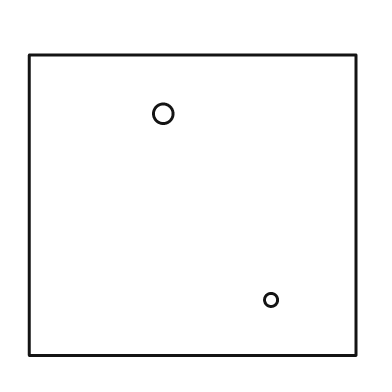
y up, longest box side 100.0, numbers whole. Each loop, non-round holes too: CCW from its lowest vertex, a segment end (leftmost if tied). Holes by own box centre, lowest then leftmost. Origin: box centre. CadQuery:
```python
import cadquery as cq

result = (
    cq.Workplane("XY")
    .moveTo(-50.0, -46.0)
    .lineTo(50.0, -46.0)
    .lineTo(50.0, 46.0)
    .lineTo(-50.0, 46.0)
    .close()
    .moveTo(24.0, -29.0)
    .circle(2.0)
    .moveTo(-9.0, 28.0)
    .circle(3.0)
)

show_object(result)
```